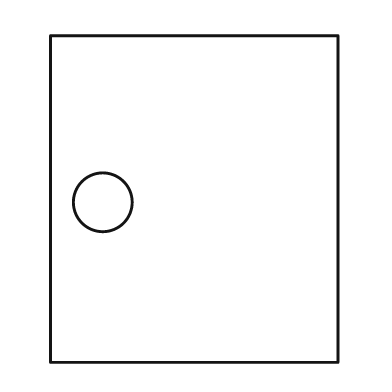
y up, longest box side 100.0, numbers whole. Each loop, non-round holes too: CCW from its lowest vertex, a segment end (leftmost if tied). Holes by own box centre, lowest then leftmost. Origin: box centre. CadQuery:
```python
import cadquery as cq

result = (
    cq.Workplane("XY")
    .moveTo(-44.0, -50.0)
    .lineTo(44.0, -50.0)
    .lineTo(44.0, 50.0)
    .lineTo(-44.0, 50.0)
    .close()
    .moveTo(-28.0, -1.0)
    .circle(9.0)
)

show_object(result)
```